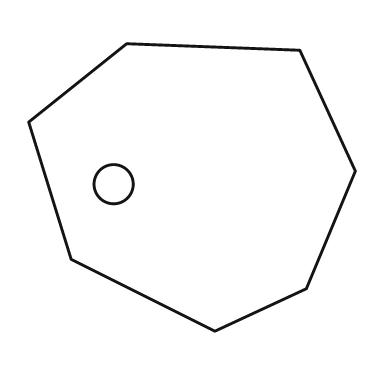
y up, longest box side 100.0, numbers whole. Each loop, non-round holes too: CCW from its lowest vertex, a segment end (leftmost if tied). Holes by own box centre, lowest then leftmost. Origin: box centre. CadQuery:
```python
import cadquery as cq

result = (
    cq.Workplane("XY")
    .moveTo(7.0, -44.0)
    .lineTo(35.0, -31.0)
    .lineTo(50.0, 5.0)
    .lineTo(33.0, 42.0)
    .lineTo(-20.0, 44.0)
    .lineTo(-50.0, 20.0)
    .lineTo(-37.0, -22.0)
    .close()
    .moveTo(-24.0, 1.0)
    .circle(6.0)
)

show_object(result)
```